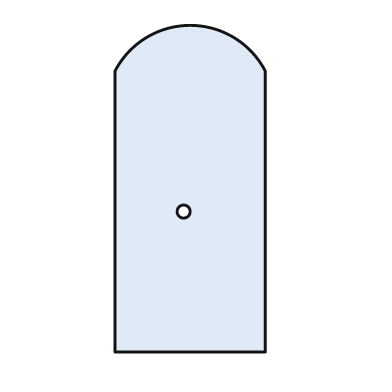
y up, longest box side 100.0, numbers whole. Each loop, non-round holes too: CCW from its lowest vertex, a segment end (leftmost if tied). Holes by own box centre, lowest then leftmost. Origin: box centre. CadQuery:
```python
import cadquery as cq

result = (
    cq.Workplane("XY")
    .moveTo(-23.0, -50.0)
    .lineTo(23.0, -50.0)
    .lineTo(23.0, 36.0)
    .threePointArc((0.0, 50.0), (-23.0, 36.0))
    .close()
    .moveTo(-2.0, -7.0)
    .circle(2.0)
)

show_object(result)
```